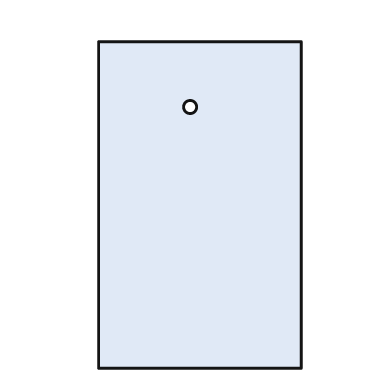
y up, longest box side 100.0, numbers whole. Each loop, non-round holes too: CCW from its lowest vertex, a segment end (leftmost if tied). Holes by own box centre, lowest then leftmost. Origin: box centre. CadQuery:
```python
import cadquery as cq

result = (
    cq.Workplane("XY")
    .moveTo(-31.0, -50.0)
    .lineTo(31.0, -50.0)
    .lineTo(31.0, 50.0)
    .lineTo(-31.0, 50.0)
    .close()
    .moveTo(-3.0, 30.0)
    .circle(2.0)
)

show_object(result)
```